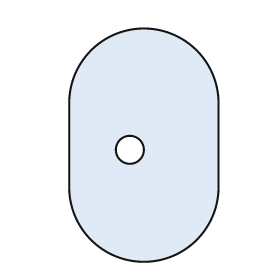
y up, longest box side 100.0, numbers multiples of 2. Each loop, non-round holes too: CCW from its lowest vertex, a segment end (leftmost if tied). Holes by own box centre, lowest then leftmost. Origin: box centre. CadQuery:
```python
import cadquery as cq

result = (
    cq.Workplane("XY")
    .moveTo(-32.0, -18.0)
    .threePointArc((0.0, -50.0), (32.0, -18.0))
    .lineTo(32.0, 18.0)
    .threePointArc((0.0, 50.0), (-32.0, 18.0))
    .close()
    .moveTo(-6.0, -2.0)
    .circle(6.0)
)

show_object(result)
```